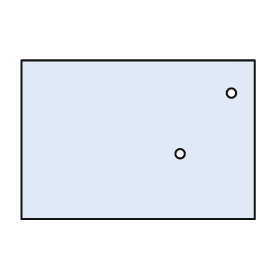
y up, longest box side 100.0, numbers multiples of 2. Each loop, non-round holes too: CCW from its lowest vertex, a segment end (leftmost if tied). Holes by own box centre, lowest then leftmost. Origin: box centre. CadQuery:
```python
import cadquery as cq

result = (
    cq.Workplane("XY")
    .moveTo(-50.0, -34.0)
    .lineTo(50.0, -34.0)
    .lineTo(50.0, 34.0)
    .lineTo(-50.0, 34.0)
    .close()
    .moveTo(18.0, -6.0)
    .circle(2.0)
    .moveTo(40.0, 20.0)
    .circle(2.0)
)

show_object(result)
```